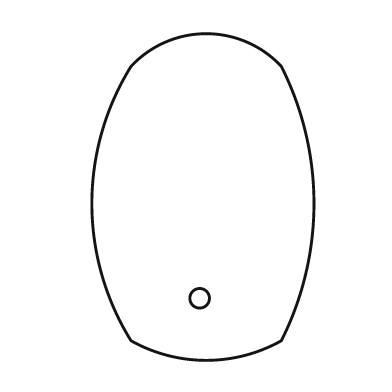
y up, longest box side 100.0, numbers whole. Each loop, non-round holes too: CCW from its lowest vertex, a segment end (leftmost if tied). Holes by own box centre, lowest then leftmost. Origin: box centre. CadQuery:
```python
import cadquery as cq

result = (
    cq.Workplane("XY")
    .moveTo(-22.0, -44.0)
    .threePointArc((1.0, -50.0), (24.0, -44.0))
    .threePointArc((34.0, -2.0), (24.0, 40.0))
    .threePointArc((1.0, 50.0), (-22.0, 40.0))
    .threePointArc((-34.0, -2.0), (-22.0, -44.0))
    .close()
    .moveTo(-1.0, -31.0)
    .circle(3.0)
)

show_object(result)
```